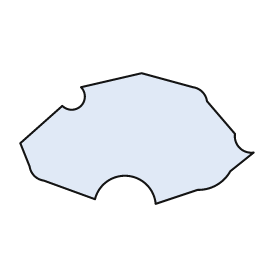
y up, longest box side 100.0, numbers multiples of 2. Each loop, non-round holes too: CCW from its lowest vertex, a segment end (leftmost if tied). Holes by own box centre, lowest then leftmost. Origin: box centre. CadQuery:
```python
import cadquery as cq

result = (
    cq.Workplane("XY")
    .moveTo(8.0, -28.0)
    .lineTo(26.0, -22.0)
    .threePointArc((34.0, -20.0), (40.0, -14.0))
    .lineTo(50.0, -6.0)
    .threePointArc((44.0, -4.0), (42.0, 2.0))
    .lineTo(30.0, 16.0)
    .threePointArc((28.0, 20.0), (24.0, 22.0))
    .lineTo(2.0, 28.0)
    .lineTo(-24.0, 22.0)
    .threePointArc((-24.0, 14.0), (-32.0, 14.0))
    .lineTo(-50.0, -2.0)
    .lineTo(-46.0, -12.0)
    .threePointArc((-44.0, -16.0), (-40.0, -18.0))
    .lineTo(-18.0, -26.0)
    .threePointArc((-4.0, -16.0), (8.0, -28.0))
    .close()
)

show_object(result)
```